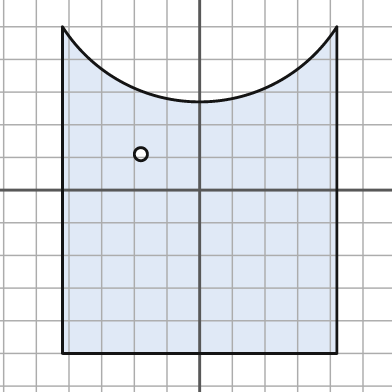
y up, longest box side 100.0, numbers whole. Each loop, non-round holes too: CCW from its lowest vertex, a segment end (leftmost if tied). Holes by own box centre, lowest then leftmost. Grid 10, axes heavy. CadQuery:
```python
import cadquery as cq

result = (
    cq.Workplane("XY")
    .moveTo(-42.0, -50.0)
    .lineTo(42.0, -50.0)
    .lineTo(42.0, 50.0)
    .threePointArc((0.0, 27.0), (-42.0, 50.0))
    .close()
    .moveTo(-18.0, 11.0)
    .circle(2.0)
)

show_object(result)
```